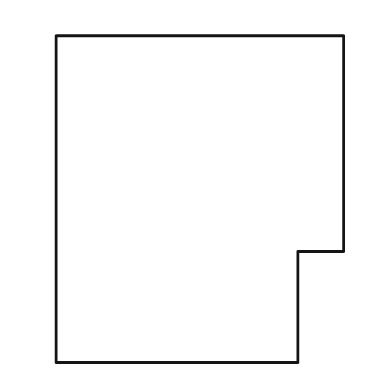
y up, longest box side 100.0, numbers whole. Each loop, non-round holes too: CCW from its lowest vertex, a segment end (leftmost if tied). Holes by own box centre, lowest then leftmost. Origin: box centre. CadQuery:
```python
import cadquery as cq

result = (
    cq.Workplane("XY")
    .moveTo(-44.0, -50.0)
    .lineTo(30.0, -50.0)
    .lineTo(30.0, -16.0)
    .lineTo(44.0, -16.0)
    .lineTo(44.0, 50.0)
    .lineTo(-44.0, 50.0)
    .close()
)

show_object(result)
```